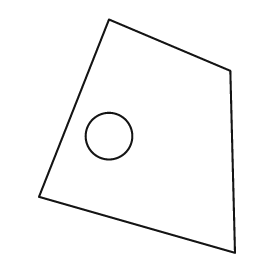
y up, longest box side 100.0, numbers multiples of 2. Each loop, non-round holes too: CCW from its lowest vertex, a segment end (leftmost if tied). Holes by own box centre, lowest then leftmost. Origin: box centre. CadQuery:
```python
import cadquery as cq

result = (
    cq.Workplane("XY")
    .moveTo(42.0, -50.0)
    .lineTo(40.0, 28.0)
    .lineTo(-12.0, 50.0)
    .lineTo(-42.0, -26.0)
    .close()
    .moveTo(-12.0, 0.0)
    .circle(10.0)
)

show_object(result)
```